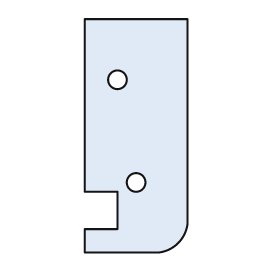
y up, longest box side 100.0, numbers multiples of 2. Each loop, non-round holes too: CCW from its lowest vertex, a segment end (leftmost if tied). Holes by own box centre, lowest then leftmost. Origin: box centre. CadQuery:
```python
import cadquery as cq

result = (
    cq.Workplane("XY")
    .moveTo(-22.0, -50.0)
    .lineTo(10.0, -50.0)
    .threePointArc((18.0, -46.0), (22.0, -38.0))
    .lineTo(22.0, 50.0)
    .lineTo(-22.0, 50.0)
    .lineTo(-22.0, -24.0)
    .lineTo(-8.0, -24.0)
    .lineTo(-8.0, -40.0)
    .lineTo(-22.0, -40.0)
    .close()
    .moveTo(0.0, -20.0)
    .circle(4.0)
    .moveTo(-8.0, 24.0)
    .circle(4.0)
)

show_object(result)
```